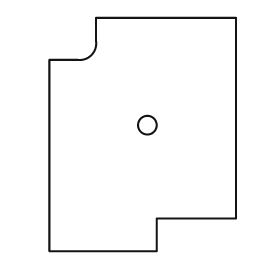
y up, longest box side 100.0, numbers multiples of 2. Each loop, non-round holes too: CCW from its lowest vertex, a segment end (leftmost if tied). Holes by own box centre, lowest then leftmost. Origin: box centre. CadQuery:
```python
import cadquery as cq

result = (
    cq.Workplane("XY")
    .moveTo(-40.0, -50.0)
    .lineTo(6.0, -50.0)
    .lineTo(6.0, -36.0)
    .lineTo(40.0, -36.0)
    .lineTo(40.0, 50.0)
    .lineTo(-20.0, 50.0)
    .lineTo(-20.0, 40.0)
    .threePointArc((-22.0, 34.0), (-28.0, 32.0))
    .lineTo(-40.0, 32.0)
    .close()
    .moveTo(2.0, 4.0)
    .circle(4.0)
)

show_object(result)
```